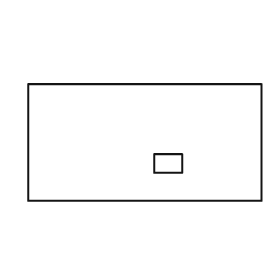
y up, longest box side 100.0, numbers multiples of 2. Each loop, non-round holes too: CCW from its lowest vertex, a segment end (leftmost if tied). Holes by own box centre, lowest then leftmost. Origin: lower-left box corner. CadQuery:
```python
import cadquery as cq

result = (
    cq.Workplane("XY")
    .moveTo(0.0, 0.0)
    .lineTo(100.0, 0.0)
    .lineTo(100.0, 50.0)
    .lineTo(0.0, 50.0)
    .close()
    .moveTo(54.0, 12.0)
    .lineTo(66.0, 12.0)
    .lineTo(66.0, 20.0)
    .lineTo(54.0, 20.0)
    .close()
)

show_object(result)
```